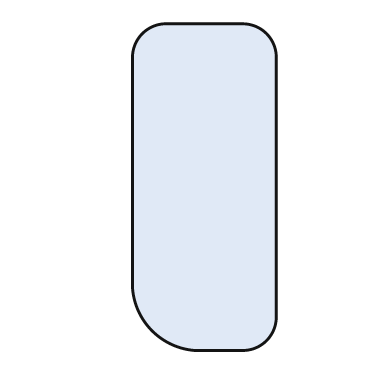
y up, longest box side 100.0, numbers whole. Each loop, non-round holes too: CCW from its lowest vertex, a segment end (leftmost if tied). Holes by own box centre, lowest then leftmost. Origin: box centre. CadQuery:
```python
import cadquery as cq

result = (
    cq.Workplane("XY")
    .moveTo(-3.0, -50.0)
    .lineTo(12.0, -50.0)
    .threePointArc((19.0, -47.0), (22.0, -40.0))
    .lineTo(22.0, 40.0)
    .threePointArc((19.0, 47.0), (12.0, 50.0))
    .lineTo(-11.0, 50.0)
    .threePointArc((-19.0, 47.0), (-22.0, 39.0))
    .lineTo(-22.0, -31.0)
    .threePointArc((-16.0, -44.0), (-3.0, -50.0))
    .close()
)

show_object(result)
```